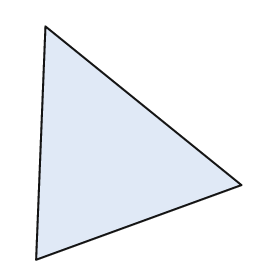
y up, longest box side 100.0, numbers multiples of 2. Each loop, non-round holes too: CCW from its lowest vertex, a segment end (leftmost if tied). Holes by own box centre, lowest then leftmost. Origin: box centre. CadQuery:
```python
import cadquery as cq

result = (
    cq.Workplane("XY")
    .moveTo(-44.0, -50.0)
    .lineTo(44.0, -18.0)
    .lineTo(-40.0, 50.0)
    .close()
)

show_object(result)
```